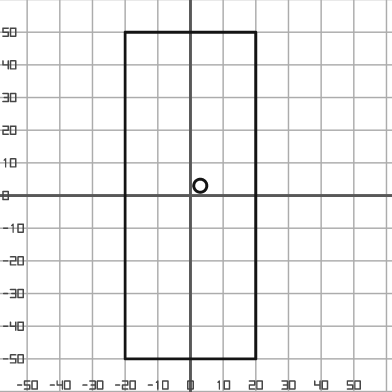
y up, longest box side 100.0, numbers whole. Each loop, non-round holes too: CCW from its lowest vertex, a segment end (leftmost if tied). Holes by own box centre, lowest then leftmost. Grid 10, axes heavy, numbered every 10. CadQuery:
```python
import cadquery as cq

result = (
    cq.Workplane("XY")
    .moveTo(-20.0, -50.0)
    .lineTo(20.0, -50.0)
    .lineTo(20.0, 50.0)
    .lineTo(-20.0, 50.0)
    .close()
    .moveTo(3.0, 3.0)
    .circle(2.0)
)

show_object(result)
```